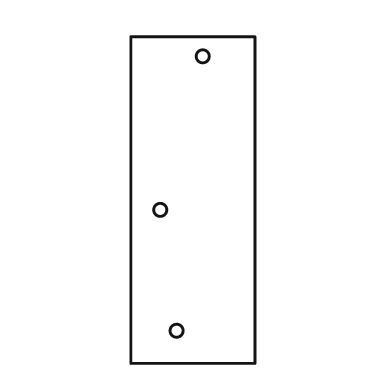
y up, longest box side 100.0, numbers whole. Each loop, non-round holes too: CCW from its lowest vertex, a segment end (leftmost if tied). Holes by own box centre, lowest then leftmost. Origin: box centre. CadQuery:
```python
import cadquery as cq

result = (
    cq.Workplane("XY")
    .moveTo(-19.0, -50.0)
    .lineTo(19.0, -50.0)
    .lineTo(19.0, 50.0)
    .lineTo(-19.0, 50.0)
    .close()
    .moveTo(-5.0, -40.0)
    .circle(2.0)
    .moveTo(-10.0, -3.0)
    .circle(2.0)
    .moveTo(3.0, 44.0)
    .circle(2.0)
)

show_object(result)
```